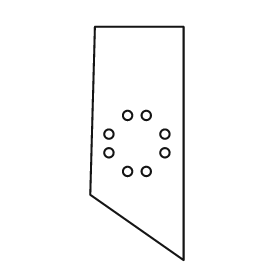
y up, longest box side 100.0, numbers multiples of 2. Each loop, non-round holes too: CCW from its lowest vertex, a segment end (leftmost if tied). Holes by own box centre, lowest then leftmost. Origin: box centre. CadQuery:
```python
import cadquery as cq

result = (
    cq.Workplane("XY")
    .moveTo(20.0, -50.0)
    .lineTo(20.0, 50.0)
    .lineTo(-18.0, 50.0)
    .lineTo(-20.0, -22.0)
    .close()
    .moveTo(-4.0, -12.0)
    .circle(2.0)
    .moveTo(4.0, -12.0)
    .circle(2.0)
    .moveTo(-12.0, -4.0)
    .circle(2.0)
    .moveTo(12.0, -4.0)
    .circle(2.0)
    .moveTo(-12.0, 4.0)
    .circle(2.0)
    .moveTo(12.0, 4.0)
    .circle(2.0)
    .moveTo(-4.0, 12.0)
    .circle(2.0)
    .moveTo(4.0, 12.0)
    .circle(2.0)
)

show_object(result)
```